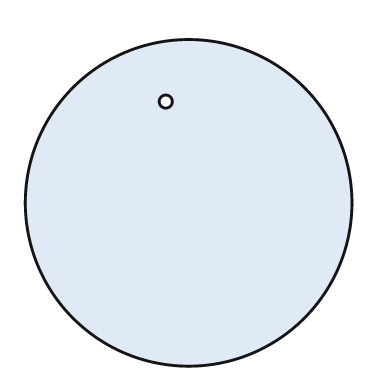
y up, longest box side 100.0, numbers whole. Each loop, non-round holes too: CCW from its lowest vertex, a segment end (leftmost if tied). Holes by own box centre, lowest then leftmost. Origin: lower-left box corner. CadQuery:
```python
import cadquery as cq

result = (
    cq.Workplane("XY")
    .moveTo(50.0, 50.0)
    .circle(50.0)
    .moveTo(43.0, 81.0)
    .circle(2.0)
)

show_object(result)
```